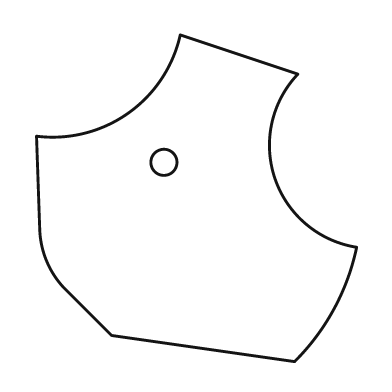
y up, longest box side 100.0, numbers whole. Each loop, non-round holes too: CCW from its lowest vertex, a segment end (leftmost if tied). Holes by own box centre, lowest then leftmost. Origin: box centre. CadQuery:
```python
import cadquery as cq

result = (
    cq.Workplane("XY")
    .moveTo(30.0, -50.0)
    .threePointArc((42.0, -34.0), (49.0, -15.0))
    .threePointArc((24.0, 6.0), (31.0, 38.0))
    .lineTo(-5.0, 50.0)
    .threePointArc((-21.0, 26.0), (-49.0, 19.0))
    .lineTo(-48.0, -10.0)
    .threePointArc((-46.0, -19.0), (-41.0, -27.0))
    .lineTo(-26.0, -42.0)
    .close()
    .moveTo(-10.0, 11.0)
    .circle(4.0)
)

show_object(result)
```